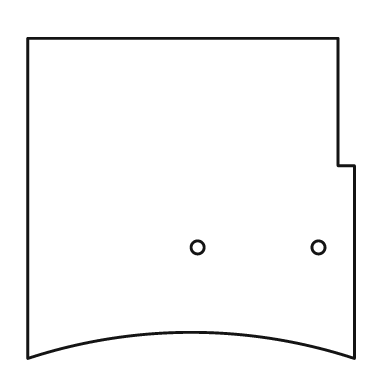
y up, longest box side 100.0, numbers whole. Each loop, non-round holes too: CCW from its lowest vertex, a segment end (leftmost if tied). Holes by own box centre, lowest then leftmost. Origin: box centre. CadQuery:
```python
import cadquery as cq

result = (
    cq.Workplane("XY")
    .moveTo(-50.0, -49.0)
    .threePointArc((0.0, -41.0), (50.0, -49.0))
    .lineTo(50.0, 10.0)
    .lineTo(45.0, 10.0)
    .lineTo(45.0, 49.0)
    .lineTo(-50.0, 49.0)
    .close()
    .moveTo(2.0, -15.0)
    .circle(2.0)
    .moveTo(39.0, -15.0)
    .circle(2.0)
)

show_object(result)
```